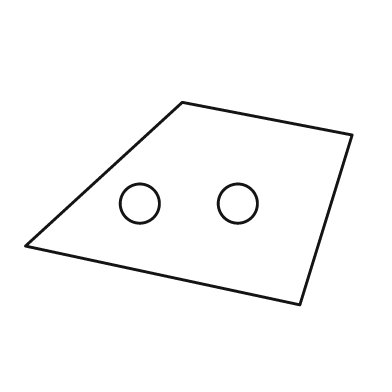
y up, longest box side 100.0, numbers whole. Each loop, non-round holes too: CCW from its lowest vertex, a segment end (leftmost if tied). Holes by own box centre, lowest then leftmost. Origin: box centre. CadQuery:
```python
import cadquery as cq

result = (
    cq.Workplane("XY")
    .moveTo(34.0, -31.0)
    .lineTo(50.0, 21.0)
    .lineTo(-2.0, 31.0)
    .lineTo(-50.0, -13.0)
    .close()
    .moveTo(-15.0, 0.0)
    .circle(6.0)
    .moveTo(15.0, 0.0)
    .circle(6.0)
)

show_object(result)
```